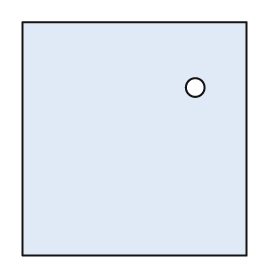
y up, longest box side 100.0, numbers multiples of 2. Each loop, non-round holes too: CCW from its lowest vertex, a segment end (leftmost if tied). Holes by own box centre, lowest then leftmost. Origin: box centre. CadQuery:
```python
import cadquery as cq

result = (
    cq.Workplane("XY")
    .moveTo(-48.0, -50.0)
    .lineTo(48.0, -50.0)
    .lineTo(48.0, 50.0)
    .lineTo(-48.0, 50.0)
    .close()
    .moveTo(26.0, 22.0)
    .circle(4.0)
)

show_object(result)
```